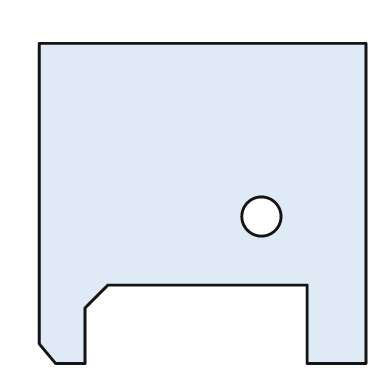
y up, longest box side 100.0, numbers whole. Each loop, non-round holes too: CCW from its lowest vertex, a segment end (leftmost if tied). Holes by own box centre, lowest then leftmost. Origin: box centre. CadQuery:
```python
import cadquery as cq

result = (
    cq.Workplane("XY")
    .moveTo(-45.0, -49.0)
    .lineTo(-36.0, -49.0)
    .lineTo(-36.0, -32.0)
    .lineTo(-29.0, -25.0)
    .lineTo(32.0, -25.0)
    .lineTo(32.0, -49.0)
    .lineTo(50.0, -49.0)
    .lineTo(50.0, 49.0)
    .lineTo(-50.0, 49.0)
    .lineTo(-50.0, -43.0)
    .close()
    .moveTo(18.0, -4.0)
    .circle(6.0)
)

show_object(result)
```